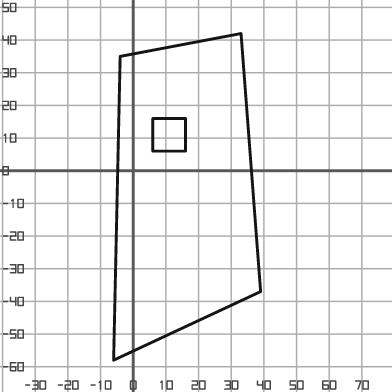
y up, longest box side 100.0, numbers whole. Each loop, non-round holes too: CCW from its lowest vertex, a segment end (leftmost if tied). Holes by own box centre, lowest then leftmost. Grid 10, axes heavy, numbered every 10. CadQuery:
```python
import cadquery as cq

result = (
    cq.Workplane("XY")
    .moveTo(-6.0, -58.0)
    .lineTo(39.0, -37.0)
    .lineTo(33.0, 42.0)
    .lineTo(-4.0, 35.0)
    .close()
    .moveTo(6.0, 6.0)
    .lineTo(16.0, 6.0)
    .lineTo(16.0, 16.0)
    .lineTo(6.0, 16.0)
    .close()
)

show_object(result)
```